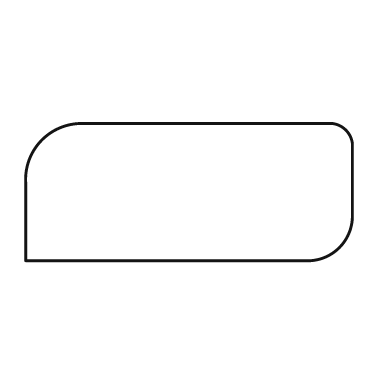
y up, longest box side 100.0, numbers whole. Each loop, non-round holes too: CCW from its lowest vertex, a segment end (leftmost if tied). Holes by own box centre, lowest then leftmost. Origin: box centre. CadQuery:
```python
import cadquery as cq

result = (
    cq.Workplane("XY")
    .moveTo(-50.0, -21.0)
    .lineTo(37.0, -21.0)
    .threePointArc((46.0, -17.0), (50.0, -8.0))
    .lineTo(50.0, 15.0)
    .threePointArc((48.0, 19.0), (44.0, 21.0))
    .lineTo(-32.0, 21.0)
    .threePointArc((-45.0, 16.0), (-50.0, 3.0))
    .close()
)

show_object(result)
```